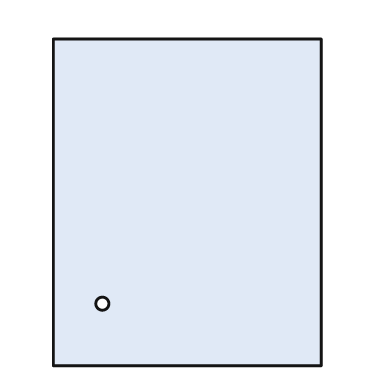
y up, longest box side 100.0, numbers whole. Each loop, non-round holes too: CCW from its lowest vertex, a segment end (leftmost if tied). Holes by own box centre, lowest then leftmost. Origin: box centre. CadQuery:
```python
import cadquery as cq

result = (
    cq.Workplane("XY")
    .moveTo(-41.0, -50.0)
    .lineTo(41.0, -50.0)
    .lineTo(41.0, 50.0)
    .lineTo(-41.0, 50.0)
    .close()
    .moveTo(-26.0, -31.0)
    .circle(2.0)
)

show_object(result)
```